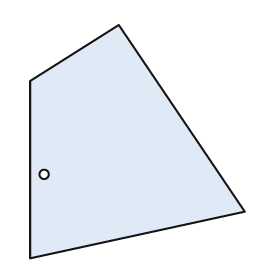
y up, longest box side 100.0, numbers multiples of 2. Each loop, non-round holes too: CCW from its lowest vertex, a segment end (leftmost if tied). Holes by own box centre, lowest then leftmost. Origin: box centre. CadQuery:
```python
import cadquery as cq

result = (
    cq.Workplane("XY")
    .moveTo(-46.0, -50.0)
    .lineTo(46.0, -30.0)
    .lineTo(-8.0, 50.0)
    .lineTo(-46.0, 26.0)
    .close()
    .moveTo(-40.0, -14.0)
    .circle(2.0)
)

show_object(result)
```